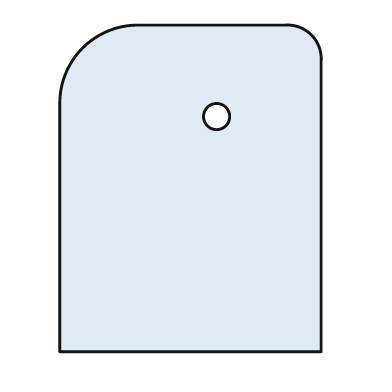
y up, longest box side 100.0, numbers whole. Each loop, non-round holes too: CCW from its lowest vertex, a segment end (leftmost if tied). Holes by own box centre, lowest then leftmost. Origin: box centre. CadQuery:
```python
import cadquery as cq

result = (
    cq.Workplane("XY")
    .moveTo(-40.0, -50.0)
    .lineTo(40.0, -50.0)
    .lineTo(40.0, 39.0)
    .threePointArc((37.0, 47.0), (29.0, 50.0))
    .lineTo(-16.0, 50.0)
    .threePointArc((-33.0, 43.0), (-40.0, 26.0))
    .close()
    .moveTo(8.0, 22.0)
    .circle(4.0)
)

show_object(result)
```